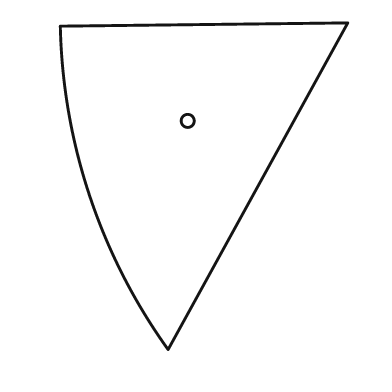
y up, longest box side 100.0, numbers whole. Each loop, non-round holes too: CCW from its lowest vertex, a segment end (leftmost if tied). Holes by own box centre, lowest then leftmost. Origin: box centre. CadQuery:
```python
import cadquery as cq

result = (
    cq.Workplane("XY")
    .moveTo(-11.0, -50.0)
    .lineTo(44.0, 50.0)
    .lineTo(-44.0, 49.0)
    .threePointArc((-35.0, -3.0), (-11.0, -50.0))
    .close()
    .moveTo(-5.0, 20.0)
    .circle(2.0)
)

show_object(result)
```